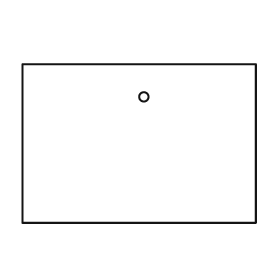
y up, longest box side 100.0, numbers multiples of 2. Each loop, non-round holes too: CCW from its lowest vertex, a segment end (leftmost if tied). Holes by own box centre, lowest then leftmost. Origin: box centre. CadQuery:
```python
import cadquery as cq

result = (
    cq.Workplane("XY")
    .moveTo(-50.0, -34.0)
    .lineTo(50.0, -34.0)
    .lineTo(50.0, 34.0)
    .lineTo(-50.0, 34.0)
    .close()
    .moveTo(2.0, 20.0)
    .circle(2.0)
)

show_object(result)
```